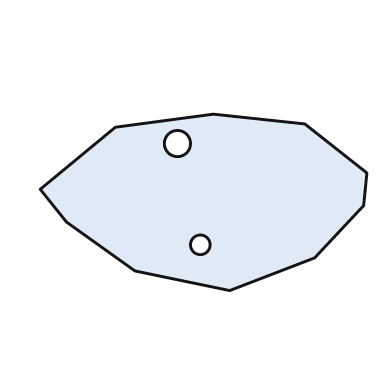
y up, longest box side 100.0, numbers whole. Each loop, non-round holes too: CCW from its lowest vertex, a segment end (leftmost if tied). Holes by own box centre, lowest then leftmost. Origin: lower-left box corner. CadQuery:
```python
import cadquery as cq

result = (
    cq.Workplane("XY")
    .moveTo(58.0, 0.0)
    .lineTo(84.0, 10.0)
    .lineTo(99.0, 26.0)
    .lineTo(100.0, 36.0)
    .lineTo(81.0, 51.0)
    .lineTo(53.0, 54.0)
    .lineTo(23.0, 50.0)
    .lineTo(0.0, 31.0)
    .lineTo(8.0, 21.0)
    .lineTo(29.0, 6.0)
    .close()
    .moveTo(49.0, 14.0)
    .circle(3.0)
    .moveTo(42.0, 45.0)
    .circle(4.0)
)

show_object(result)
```